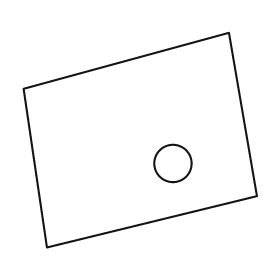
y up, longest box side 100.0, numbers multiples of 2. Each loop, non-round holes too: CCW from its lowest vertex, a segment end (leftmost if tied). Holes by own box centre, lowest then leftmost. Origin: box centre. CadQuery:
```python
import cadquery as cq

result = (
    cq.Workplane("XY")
    .moveTo(-40.0, -46.0)
    .lineTo(50.0, -24.0)
    .lineTo(38.0, 46.0)
    .lineTo(-50.0, 22.0)
    .close()
    .moveTo(14.0, -10.0)
    .circle(8.0)
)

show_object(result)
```